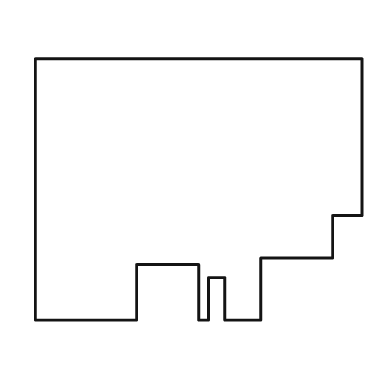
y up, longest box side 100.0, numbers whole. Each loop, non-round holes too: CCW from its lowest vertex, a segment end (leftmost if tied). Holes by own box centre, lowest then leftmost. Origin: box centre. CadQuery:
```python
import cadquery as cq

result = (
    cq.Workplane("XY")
    .moveTo(-50.0, -40.0)
    .lineTo(-19.0, -40.0)
    .lineTo(-19.0, -23.0)
    .lineTo(0.0, -23.0)
    .lineTo(0.0, -40.0)
    .lineTo(3.0, -40.0)
    .lineTo(3.0, -27.0)
    .lineTo(8.0, -27.0)
    .lineTo(8.0, -40.0)
    .lineTo(19.0, -40.0)
    .lineTo(19.0, -21.0)
    .lineTo(41.0, -21.0)
    .lineTo(41.0, -8.0)
    .lineTo(50.0, -8.0)
    .lineTo(50.0, 40.0)
    .lineTo(-50.0, 40.0)
    .close()
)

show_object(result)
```